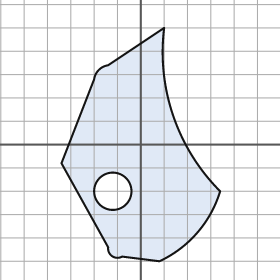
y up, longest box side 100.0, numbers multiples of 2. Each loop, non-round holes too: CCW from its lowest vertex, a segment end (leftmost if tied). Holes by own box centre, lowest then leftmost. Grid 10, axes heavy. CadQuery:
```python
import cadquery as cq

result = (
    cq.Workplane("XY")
    .moveTo(8.0, -50.0)
    .threePointArc((24.0, -38.0), (34.0, -20.0))
    .threePointArc((14.0, 12.0), (10.0, 50.0))
    .lineTo(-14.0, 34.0)
    .threePointArc((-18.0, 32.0), (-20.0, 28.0))
    .lineTo(-34.0, -8.0)
    .lineTo(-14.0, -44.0)
    .threePointArc((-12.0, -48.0), (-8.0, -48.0))
    .close()
    .moveTo(-12.0, -20.0)
    .circle(8.0)
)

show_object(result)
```